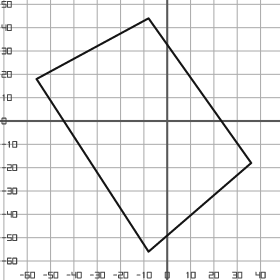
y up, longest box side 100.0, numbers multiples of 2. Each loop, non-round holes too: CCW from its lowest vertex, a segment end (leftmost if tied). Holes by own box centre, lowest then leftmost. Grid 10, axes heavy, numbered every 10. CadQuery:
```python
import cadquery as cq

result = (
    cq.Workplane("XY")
    .moveTo(-8.0, -56.0)
    .lineTo(36.0, -18.0)
    .lineTo(-8.0, 44.0)
    .lineTo(-56.0, 18.0)
    .close()
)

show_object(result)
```